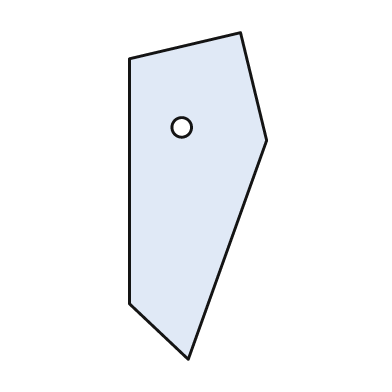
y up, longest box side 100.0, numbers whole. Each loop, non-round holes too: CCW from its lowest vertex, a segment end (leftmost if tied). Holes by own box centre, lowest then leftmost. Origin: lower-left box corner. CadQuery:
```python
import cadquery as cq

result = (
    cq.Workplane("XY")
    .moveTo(18.0, 0.0)
    .lineTo(42.0, 67.0)
    .lineTo(34.0, 100.0)
    .lineTo(0.0, 92.0)
    .lineTo(0.0, 17.0)
    .close()
    .moveTo(16.0, 71.0)
    .circle(3.0)
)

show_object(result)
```